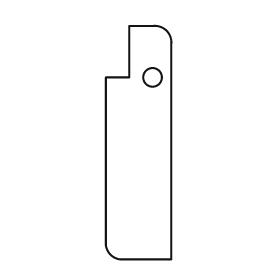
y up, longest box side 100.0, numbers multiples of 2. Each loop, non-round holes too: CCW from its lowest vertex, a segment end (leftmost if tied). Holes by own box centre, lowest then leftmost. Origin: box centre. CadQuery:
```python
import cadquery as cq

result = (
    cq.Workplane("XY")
    .moveTo(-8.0, -50.0)
    .lineTo(14.0, -50.0)
    .lineTo(14.0, 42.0)
    .threePointArc((12.0, 48.0), (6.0, 50.0))
    .lineTo(-4.0, 50.0)
    .lineTo(-4.0, 28.0)
    .lineTo(-14.0, 28.0)
    .lineTo(-14.0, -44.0)
    .threePointArc((-12.0, -48.0), (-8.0, -50.0))
    .close()
    .moveTo(6.0, 28.0)
    .circle(4.0)
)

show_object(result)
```